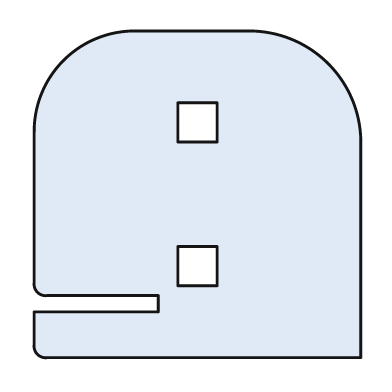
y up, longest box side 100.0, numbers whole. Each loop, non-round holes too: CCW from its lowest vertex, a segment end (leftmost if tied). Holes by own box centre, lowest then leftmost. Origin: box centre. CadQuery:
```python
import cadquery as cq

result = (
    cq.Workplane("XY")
    .moveTo(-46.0, -50.0)
    .lineTo(50.0, -50.0)
    .lineTo(50.0, 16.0)
    .threePointArc((40.0, 40.0), (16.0, 50.0))
    .lineTo(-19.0, 50.0)
    .threePointArc((-41.0, 41.0), (-50.0, 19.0))
    .lineTo(-50.0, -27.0)
    .threePointArc((-49.0, -30.0), (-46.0, -31.0))
    .lineTo(-12.0, -31.0)
    .lineTo(-12.0, -36.0)
    .lineTo(-50.0, -36.0)
    .lineTo(-50.0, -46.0)
    .threePointArc((-49.0, -49.0), (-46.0, -50.0))
    .close()
    .moveTo(-6.0, -28.0)
    .lineTo(6.0, -28.0)
    .lineTo(6.0, -16.0)
    .lineTo(-6.0, -16.0)
    .close()
    .moveTo(-6.0, 16.0)
    .lineTo(6.0, 16.0)
    .lineTo(6.0, 28.0)
    .lineTo(-6.0, 28.0)
    .close()
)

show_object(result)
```